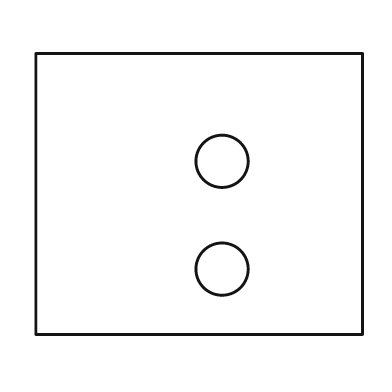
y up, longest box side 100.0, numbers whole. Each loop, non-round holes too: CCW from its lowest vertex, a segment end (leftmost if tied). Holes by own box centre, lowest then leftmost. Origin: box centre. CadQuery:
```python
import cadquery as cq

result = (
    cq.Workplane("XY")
    .moveTo(-50.0, -43.0)
    .lineTo(50.0, -43.0)
    .lineTo(50.0, 43.0)
    .lineTo(-50.0, 43.0)
    .close()
    .moveTo(7.0, -23.0)
    .circle(8.0)
    .moveTo(7.0, 10.0)
    .circle(8.0)
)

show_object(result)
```